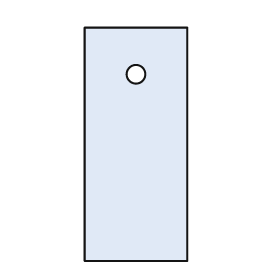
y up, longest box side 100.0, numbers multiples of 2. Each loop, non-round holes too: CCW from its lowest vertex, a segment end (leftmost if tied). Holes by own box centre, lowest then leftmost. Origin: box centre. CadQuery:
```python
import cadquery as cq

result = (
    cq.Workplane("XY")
    .moveTo(-22.0, -50.0)
    .lineTo(22.0, -50.0)
    .lineTo(22.0, 50.0)
    .lineTo(-22.0, 50.0)
    .close()
    .moveTo(0.0, 30.0)
    .circle(4.0)
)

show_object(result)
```